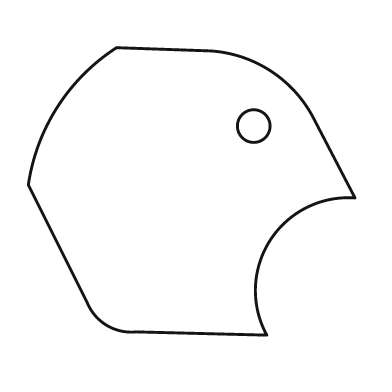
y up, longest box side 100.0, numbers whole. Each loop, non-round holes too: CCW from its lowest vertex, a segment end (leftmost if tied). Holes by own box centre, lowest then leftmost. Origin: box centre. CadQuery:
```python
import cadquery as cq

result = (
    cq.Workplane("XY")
    .moveTo(23.0, -44.0)
    .threePointArc((24.0, -15.0), (50.0, -2.0))
    .lineTo(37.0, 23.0)
    .threePointArc((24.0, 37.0), (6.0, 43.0))
    .lineTo(-23.0, 44.0)
    .threePointArc((-41.0, 26.0), (-50.0, 2.0))
    .lineTo(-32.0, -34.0)
    .threePointArc((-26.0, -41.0), (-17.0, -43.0))
    .close()
    .moveTo(19.0, 20.0)
    .circle(5.0)
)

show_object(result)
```